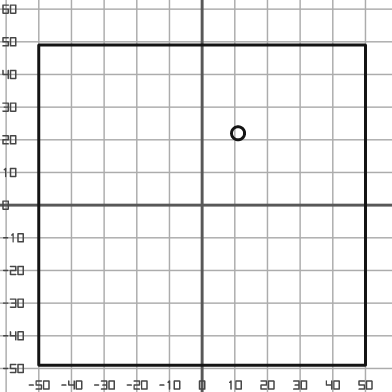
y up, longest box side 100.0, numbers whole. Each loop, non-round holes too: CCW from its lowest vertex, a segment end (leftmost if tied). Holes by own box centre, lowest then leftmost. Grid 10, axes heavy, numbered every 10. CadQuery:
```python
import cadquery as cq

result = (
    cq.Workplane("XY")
    .moveTo(-50.0, -49.0)
    .lineTo(50.0, -49.0)
    .lineTo(50.0, 49.0)
    .lineTo(-50.0, 49.0)
    .close()
    .moveTo(11.0, 22.0)
    .circle(2.0)
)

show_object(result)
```